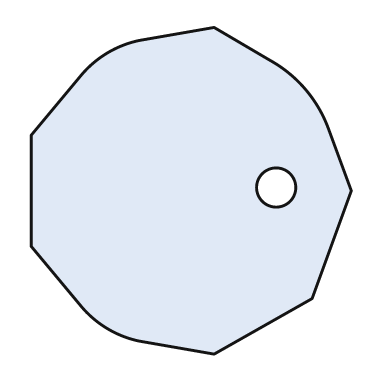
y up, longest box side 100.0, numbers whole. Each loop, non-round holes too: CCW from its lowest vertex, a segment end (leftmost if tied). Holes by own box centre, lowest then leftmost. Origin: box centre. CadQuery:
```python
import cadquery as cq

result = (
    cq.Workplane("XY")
    .moveTo(7.0, -50.0)
    .lineTo(37.0, -33.0)
    .lineTo(49.0, 0.0)
    .lineTo(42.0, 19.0)
    .threePointArc((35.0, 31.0), (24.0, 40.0))
    .lineTo(7.0, 50.0)
    .lineTo(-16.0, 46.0)
    .threePointArc((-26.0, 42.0), (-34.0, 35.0))
    .lineTo(-49.0, 17.0)
    .lineTo(-49.0, -17.0)
    .lineTo(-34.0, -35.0)
    .threePointArc((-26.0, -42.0), (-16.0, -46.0))
    .close()
    .moveTo(26.0, 1.0)
    .circle(6.0)
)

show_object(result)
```